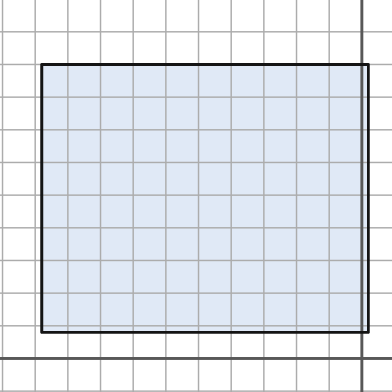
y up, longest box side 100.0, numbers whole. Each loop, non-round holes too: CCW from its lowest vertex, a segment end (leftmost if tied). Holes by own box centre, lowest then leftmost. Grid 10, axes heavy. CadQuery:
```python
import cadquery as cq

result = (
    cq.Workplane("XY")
    .moveTo(-98.0, 8.0)
    .lineTo(2.0, 8.0)
    .lineTo(2.0, 90.0)
    .lineTo(-98.0, 90.0)
    .close()
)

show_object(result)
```